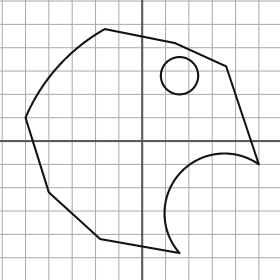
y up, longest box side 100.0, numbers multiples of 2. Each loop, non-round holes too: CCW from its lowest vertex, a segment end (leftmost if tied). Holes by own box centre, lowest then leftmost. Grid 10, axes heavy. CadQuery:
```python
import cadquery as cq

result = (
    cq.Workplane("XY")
    .moveTo(16.0, -48.0)
    .threePointArc((16.0, -14.0), (50.0, -10.0))
    .lineTo(36.0, 32.0)
    .lineTo(14.0, 42.0)
    .lineTo(-16.0, 48.0)
    .threePointArc((-36.0, 32.0), (-50.0, 10.0))
    .lineTo(-40.0, -22.0)
    .lineTo(-18.0, -42.0)
    .close()
    .moveTo(16.0, 28.0)
    .circle(8.0)
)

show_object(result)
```